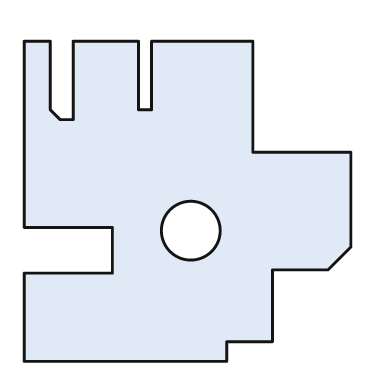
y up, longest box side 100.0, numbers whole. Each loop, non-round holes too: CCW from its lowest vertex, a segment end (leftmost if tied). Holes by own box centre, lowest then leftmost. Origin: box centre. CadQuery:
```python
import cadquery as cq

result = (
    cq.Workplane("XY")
    .moveTo(-50.0, -49.0)
    .lineTo(12.0, -49.0)
    .lineTo(12.0, -43.0)
    .lineTo(26.0, -43.0)
    .lineTo(26.0, -21.0)
    .lineTo(43.0, -21.0)
    .lineTo(50.0, -14.0)
    .lineTo(50.0, 15.0)
    .lineTo(20.0, 15.0)
    .lineTo(20.0, 49.0)
    .lineTo(-11.0, 49.0)
    .lineTo(-11.0, 28.0)
    .lineTo(-15.0, 28.0)
    .lineTo(-15.0, 49.0)
    .lineTo(-35.0, 49.0)
    .lineTo(-35.0, 25.0)
    .lineTo(-39.0, 25.0)
    .lineTo(-42.0, 28.0)
    .lineTo(-42.0, 49.0)
    .lineTo(-50.0, 49.0)
    .lineTo(-50.0, -8.0)
    .lineTo(-23.0, -8.0)
    .lineTo(-23.0, -22.0)
    .lineTo(-50.0, -22.0)
    .close()
    .moveTo(1.0, -9.0)
    .circle(9.0)
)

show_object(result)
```